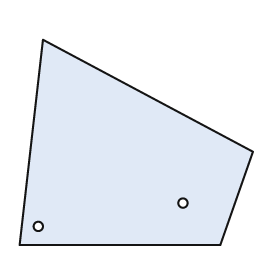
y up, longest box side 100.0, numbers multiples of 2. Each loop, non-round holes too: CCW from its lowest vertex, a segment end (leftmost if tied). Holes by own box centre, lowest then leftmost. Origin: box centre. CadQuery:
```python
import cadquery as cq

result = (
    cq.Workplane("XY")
    .moveTo(-50.0, -44.0)
    .lineTo(36.0, -44.0)
    .lineTo(50.0, -4.0)
    .lineTo(-40.0, 44.0)
    .close()
    .moveTo(-42.0, -36.0)
    .circle(2.0)
    .moveTo(20.0, -26.0)
    .circle(2.0)
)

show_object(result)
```